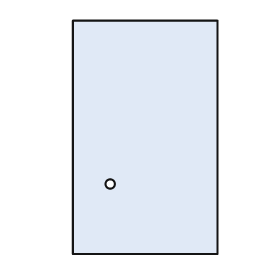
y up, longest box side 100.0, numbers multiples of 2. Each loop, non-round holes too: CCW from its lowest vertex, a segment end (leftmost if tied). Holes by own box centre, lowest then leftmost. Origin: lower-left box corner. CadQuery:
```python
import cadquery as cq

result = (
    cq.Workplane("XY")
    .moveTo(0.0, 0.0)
    .lineTo(62.0, 0.0)
    .lineTo(62.0, 100.0)
    .lineTo(0.0, 100.0)
    .close()
    .moveTo(16.0, 30.0)
    .circle(2.0)
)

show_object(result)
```